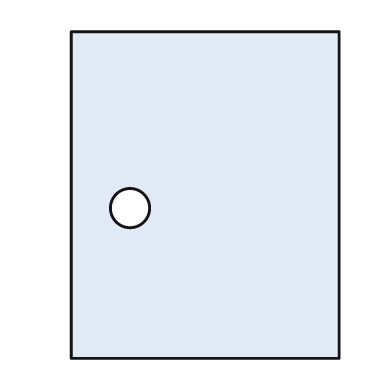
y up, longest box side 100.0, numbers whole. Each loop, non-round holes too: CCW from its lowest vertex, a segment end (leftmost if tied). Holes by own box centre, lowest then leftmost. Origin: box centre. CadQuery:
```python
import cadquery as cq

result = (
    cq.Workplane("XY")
    .moveTo(-41.0, -50.0)
    .lineTo(41.0, -50.0)
    .lineTo(41.0, 50.0)
    .lineTo(-41.0, 50.0)
    .close()
    .moveTo(-23.0, -4.0)
    .circle(6.0)
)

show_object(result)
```